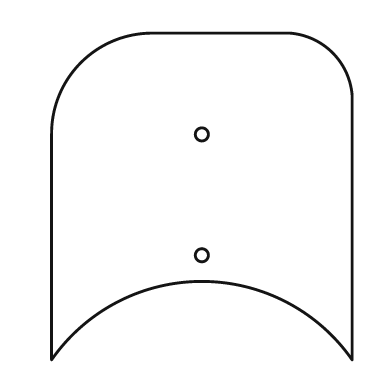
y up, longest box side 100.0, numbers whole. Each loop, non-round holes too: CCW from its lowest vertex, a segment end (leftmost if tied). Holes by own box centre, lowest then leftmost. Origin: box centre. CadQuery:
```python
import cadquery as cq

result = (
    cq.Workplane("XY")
    .moveTo(-46.0, -50.0)
    .threePointArc((0.0, -26.0), (46.0, -50.0))
    .lineTo(46.0, 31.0)
    .threePointArc((40.0, 44.0), (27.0, 50.0))
    .lineTo(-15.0, 50.0)
    .threePointArc((-37.0, 41.0), (-46.0, 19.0))
    .close()
    .moveTo(0.0, -18.0)
    .circle(2.0)
    .moveTo(0.0, 19.0)
    .circle(2.0)
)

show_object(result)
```